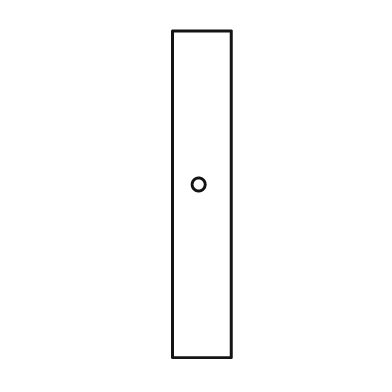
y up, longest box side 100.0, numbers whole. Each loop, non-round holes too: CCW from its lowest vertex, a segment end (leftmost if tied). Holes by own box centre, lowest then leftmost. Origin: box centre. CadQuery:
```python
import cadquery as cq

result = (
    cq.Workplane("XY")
    .moveTo(-9.0, -50.0)
    .lineTo(9.0, -50.0)
    .lineTo(9.0, 50.0)
    .lineTo(-9.0, 50.0)
    .close()
    .moveTo(-1.0, 3.0)
    .circle(2.0)
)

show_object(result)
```